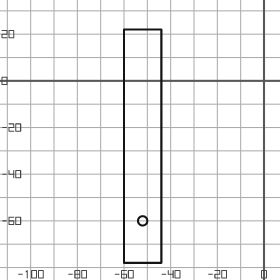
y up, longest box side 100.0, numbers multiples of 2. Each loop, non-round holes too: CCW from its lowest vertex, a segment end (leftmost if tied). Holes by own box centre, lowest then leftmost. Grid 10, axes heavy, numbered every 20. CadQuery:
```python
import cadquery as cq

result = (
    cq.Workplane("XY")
    .moveTo(-60.0, -78.0)
    .lineTo(-44.0, -78.0)
    .lineTo(-44.0, 22.0)
    .lineTo(-60.0, 22.0)
    .close()
    .moveTo(-52.0, -60.0)
    .circle(2.0)
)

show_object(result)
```